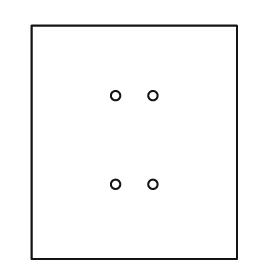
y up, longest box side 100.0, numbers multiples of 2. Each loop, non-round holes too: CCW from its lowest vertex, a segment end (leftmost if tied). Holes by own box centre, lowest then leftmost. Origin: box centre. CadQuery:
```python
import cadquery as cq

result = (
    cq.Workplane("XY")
    .moveTo(-44.0, -50.0)
    .lineTo(44.0, -50.0)
    .lineTo(44.0, 50.0)
    .lineTo(-44.0, 50.0)
    .close()
    .moveTo(-8.0, -18.0)
    .circle(2.0)
    .moveTo(8.0, -18.0)
    .circle(2.0)
    .moveTo(-8.0, 20.0)
    .circle(2.0)
    .moveTo(8.0, 20.0)
    .circle(2.0)
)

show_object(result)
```